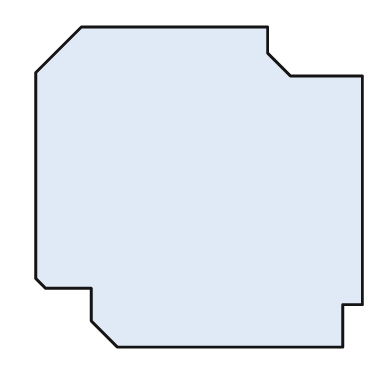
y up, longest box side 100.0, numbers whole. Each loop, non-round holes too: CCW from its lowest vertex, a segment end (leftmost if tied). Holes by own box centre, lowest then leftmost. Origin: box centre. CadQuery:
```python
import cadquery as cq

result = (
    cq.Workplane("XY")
    .moveTo(-25.0, -49.0)
    .lineTo(44.0, -49.0)
    .lineTo(44.0, -36.0)
    .lineTo(50.0, -36.0)
    .lineTo(50.0, 34.0)
    .lineTo(28.0, 34.0)
    .lineTo(21.0, 41.0)
    .lineTo(21.0, 49.0)
    .lineTo(-36.0, 49.0)
    .lineTo(-50.0, 35.0)
    .lineTo(-50.0, -28.0)
    .lineTo(-47.0, -31.0)
    .lineTo(-33.0, -31.0)
    .lineTo(-33.0, -41.0)
    .close()
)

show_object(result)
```